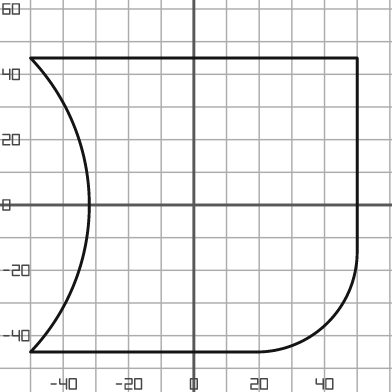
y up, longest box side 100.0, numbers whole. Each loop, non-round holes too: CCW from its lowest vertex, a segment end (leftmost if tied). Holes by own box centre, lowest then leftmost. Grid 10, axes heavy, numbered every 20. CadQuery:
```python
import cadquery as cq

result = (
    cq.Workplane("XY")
    .moveTo(-50.0, -45.0)
    .lineTo(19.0, -45.0)
    .threePointArc((41.0, -36.0), (50.0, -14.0))
    .lineTo(50.0, 45.0)
    .lineTo(-50.0, 45.0)
    .threePointArc((-32.0, 0.0), (-50.0, -45.0))
    .close()
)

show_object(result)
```